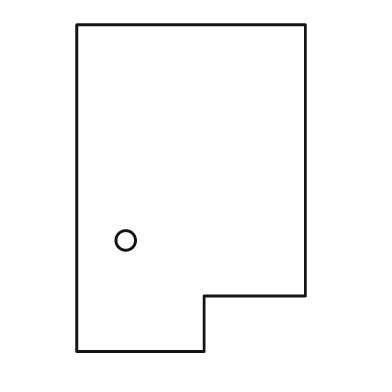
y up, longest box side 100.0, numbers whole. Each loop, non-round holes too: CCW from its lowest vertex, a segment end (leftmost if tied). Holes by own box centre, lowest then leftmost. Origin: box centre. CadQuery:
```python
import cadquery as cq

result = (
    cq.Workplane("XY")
    .moveTo(-35.0, -50.0)
    .lineTo(4.0, -50.0)
    .lineTo(4.0, -33.0)
    .lineTo(35.0, -33.0)
    .lineTo(35.0, 50.0)
    .lineTo(-35.0, 50.0)
    .close()
    .moveTo(-20.0, -16.0)
    .circle(3.0)
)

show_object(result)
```